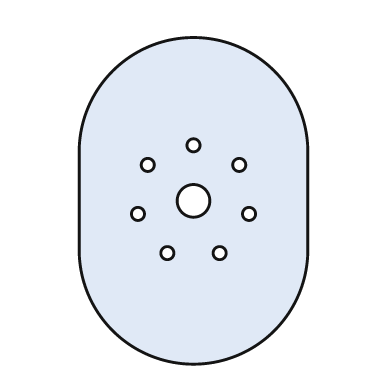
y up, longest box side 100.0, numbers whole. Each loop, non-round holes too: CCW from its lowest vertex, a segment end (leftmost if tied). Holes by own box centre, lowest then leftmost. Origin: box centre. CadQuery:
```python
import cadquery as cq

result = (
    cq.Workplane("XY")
    .moveTo(-35.0, -15.0)
    .threePointArc((0.0, -50.0), (35.0, -15.0))
    .lineTo(35.0, 15.0)
    .threePointArc((0.0, 50.0), (-35.0, 15.0))
    .close()
    .moveTo(-8.0, -16.0)
    .circle(2.0)
    .moveTo(8.0, -16.0)
    .circle(2.0)
    .moveTo(-17.0, -4.0)
    .circle(2.0)
    .moveTo(17.0, -4.0)
    .circle(2.0)
    .moveTo(0.0, 0.0)
    .circle(5.0)
    .moveTo(-14.0, 11.0)
    .circle(2.0)
    .moveTo(14.0, 11.0)
    .circle(2.0)
    .moveTo(0.0, 17.0)
    .circle(2.0)
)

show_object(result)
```